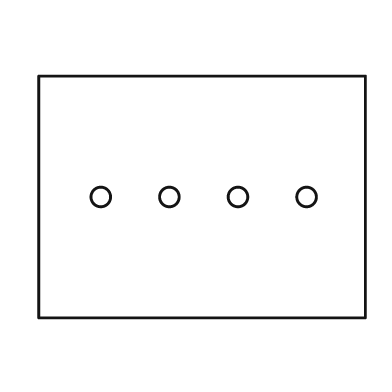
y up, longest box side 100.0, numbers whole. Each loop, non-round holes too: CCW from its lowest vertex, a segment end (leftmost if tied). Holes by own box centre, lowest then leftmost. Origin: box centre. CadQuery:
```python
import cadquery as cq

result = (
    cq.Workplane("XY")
    .moveTo(-50.0, -37.0)
    .lineTo(50.0, -37.0)
    .lineTo(50.0, 37.0)
    .lineTo(-50.0, 37.0)
    .close()
    .moveTo(-31.0, 0.0)
    .circle(3.0)
    .moveTo(-10.0, 0.0)
    .circle(3.0)
    .moveTo(11.0, 0.0)
    .circle(3.0)
    .moveTo(32.0, 0.0)
    .circle(3.0)
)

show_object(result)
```